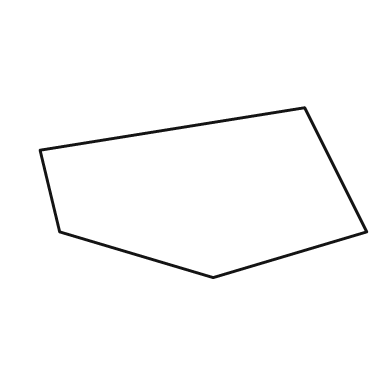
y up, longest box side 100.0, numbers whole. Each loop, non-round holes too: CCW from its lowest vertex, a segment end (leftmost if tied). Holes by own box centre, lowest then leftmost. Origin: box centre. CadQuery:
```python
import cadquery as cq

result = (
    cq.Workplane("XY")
    .moveTo(3.0, -26.0)
    .lineTo(50.0, -12.0)
    .lineTo(31.0, 26.0)
    .lineTo(-50.0, 13.0)
    .lineTo(-44.0, -12.0)
    .close()
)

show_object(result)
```